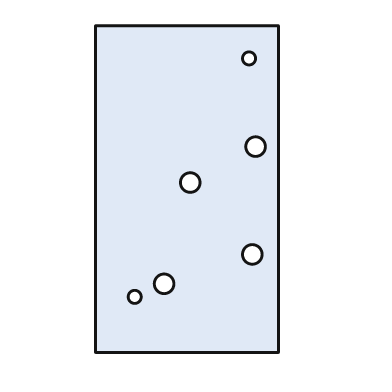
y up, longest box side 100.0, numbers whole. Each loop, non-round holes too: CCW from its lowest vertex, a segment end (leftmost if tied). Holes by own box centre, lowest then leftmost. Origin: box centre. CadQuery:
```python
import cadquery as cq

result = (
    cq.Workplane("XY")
    .moveTo(-28.0, -50.0)
    .lineTo(28.0, -50.0)
    .lineTo(28.0, 50.0)
    .lineTo(-28.0, 50.0)
    .close()
    .moveTo(-16.0, -33.0)
    .circle(2.0)
    .moveTo(-7.0, -29.0)
    .circle(3.0)
    .moveTo(20.0, -20.0)
    .circle(3.0)
    .moveTo(1.0, 2.0)
    .circle(3.0)
    .moveTo(21.0, 13.0)
    .circle(3.0)
    .moveTo(19.0, 40.0)
    .circle(2.0)
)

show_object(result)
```